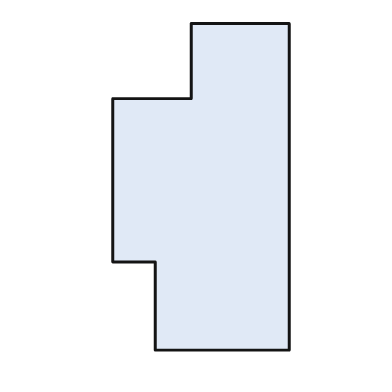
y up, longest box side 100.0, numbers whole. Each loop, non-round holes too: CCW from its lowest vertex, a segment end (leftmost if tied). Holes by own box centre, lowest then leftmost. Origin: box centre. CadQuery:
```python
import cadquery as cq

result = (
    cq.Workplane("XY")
    .moveTo(-14.0, -50.0)
    .lineTo(27.0, -50.0)
    .lineTo(27.0, 50.0)
    .lineTo(-3.0, 50.0)
    .lineTo(-3.0, 27.0)
    .lineTo(-27.0, 27.0)
    .lineTo(-27.0, -23.0)
    .lineTo(-14.0, -23.0)
    .close()
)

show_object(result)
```